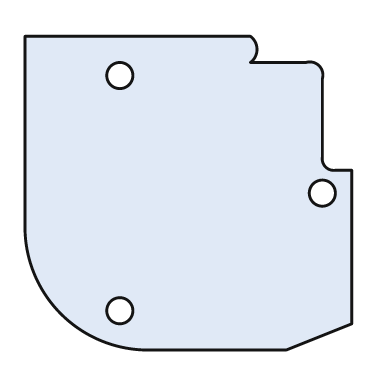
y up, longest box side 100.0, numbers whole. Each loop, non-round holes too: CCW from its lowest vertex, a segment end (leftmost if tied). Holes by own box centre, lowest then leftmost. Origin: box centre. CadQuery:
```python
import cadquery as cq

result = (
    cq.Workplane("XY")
    .moveTo(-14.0, -48.0)
    .lineTo(30.0, -48.0)
    .lineTo(50.0, -40.0)
    .lineTo(50.0, 7.0)
    .lineTo(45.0, 7.0)
    .threePointArc((42.0, 8.0), (41.0, 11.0))
    .lineTo(41.0, 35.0)
    .threePointArc((40.0, 39.0), (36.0, 40.0))
    .lineTo(19.0, 40.0)
    .threePointArc((21.0, 44.0), (19.0, 48.0))
    .lineTo(-50.0, 48.0)
    .lineTo(-50.0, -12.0)
    .threePointArc((-39.0, -37.0), (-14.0, -48.0))
    .close()
    .moveTo(-21.0, -36.0)
    .circle(4.0)
    .moveTo(41.0, 0.0)
    .circle(4.0)
    .moveTo(-21.0, 36.0)
    .circle(4.0)
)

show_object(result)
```